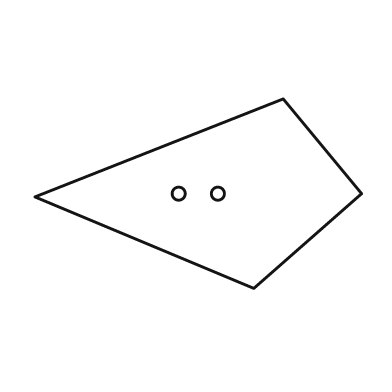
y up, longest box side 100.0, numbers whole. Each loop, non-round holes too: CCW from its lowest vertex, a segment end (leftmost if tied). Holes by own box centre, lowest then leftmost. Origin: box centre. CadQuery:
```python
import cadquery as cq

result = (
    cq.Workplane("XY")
    .moveTo(17.0, -29.0)
    .lineTo(50.0, 0.0)
    .lineTo(26.0, 29.0)
    .lineTo(-50.0, -1.0)
    .close()
    .moveTo(-6.0, 0.0)
    .circle(2.0)
    .moveTo(6.0, 0.0)
    .circle(2.0)
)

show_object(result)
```